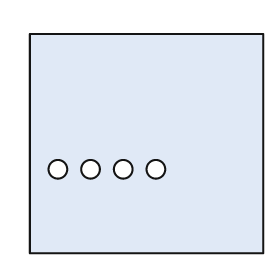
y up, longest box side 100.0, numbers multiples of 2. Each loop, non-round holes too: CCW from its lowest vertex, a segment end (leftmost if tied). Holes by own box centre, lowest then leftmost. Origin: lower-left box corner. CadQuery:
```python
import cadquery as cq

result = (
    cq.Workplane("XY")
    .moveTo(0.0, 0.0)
    .lineTo(100.0, 0.0)
    .lineTo(100.0, 94.0)
    .lineTo(0.0, 94.0)
    .close()
    .moveTo(12.0, 36.0)
    .circle(4.0)
    .moveTo(26.0, 36.0)
    .circle(4.0)
    .moveTo(40.0, 36.0)
    .circle(4.0)
    .moveTo(54.0, 36.0)
    .circle(4.0)
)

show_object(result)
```